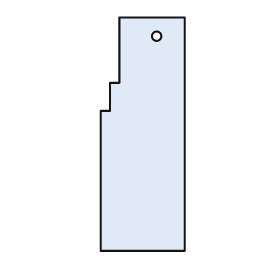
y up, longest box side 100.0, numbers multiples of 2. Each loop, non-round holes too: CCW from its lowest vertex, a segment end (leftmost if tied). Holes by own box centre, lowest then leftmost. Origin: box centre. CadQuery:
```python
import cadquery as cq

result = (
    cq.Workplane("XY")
    .moveTo(-18.0, -50.0)
    .lineTo(18.0, -50.0)
    .lineTo(18.0, 50.0)
    .lineTo(-10.0, 50.0)
    .lineTo(-10.0, 22.0)
    .lineTo(-14.0, 22.0)
    .lineTo(-14.0, 10.0)
    .lineTo(-18.0, 10.0)
    .close()
    .moveTo(6.0, 42.0)
    .circle(2.0)
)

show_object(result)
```